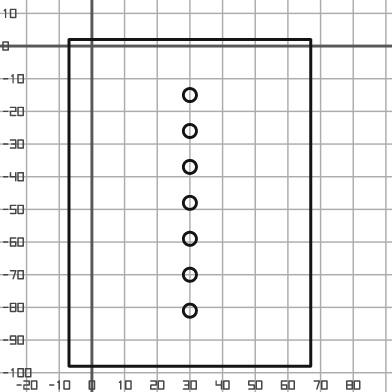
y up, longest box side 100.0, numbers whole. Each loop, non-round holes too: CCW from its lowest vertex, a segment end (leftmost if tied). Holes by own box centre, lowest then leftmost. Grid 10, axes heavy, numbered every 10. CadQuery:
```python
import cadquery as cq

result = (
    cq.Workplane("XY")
    .moveTo(-7.0, -98.0)
    .lineTo(67.0, -98.0)
    .lineTo(67.0, 2.0)
    .lineTo(-7.0, 2.0)
    .close()
    .moveTo(30.0, -81.0)
    .circle(2.0)
    .moveTo(30.0, -70.0)
    .circle(2.0)
    .moveTo(30.0, -59.0)
    .circle(2.0)
    .moveTo(30.0, -48.0)
    .circle(2.0)
    .moveTo(30.0, -37.0)
    .circle(2.0)
    .moveTo(30.0, -26.0)
    .circle(2.0)
    .moveTo(30.0, -15.0)
    .circle(2.0)
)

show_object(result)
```